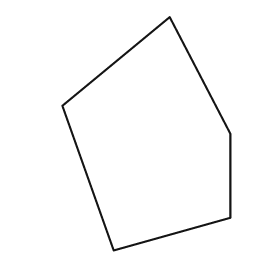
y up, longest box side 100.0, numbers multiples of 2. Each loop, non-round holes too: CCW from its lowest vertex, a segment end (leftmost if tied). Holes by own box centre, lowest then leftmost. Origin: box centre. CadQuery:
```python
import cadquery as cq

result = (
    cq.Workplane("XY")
    .moveTo(-14.0, -50.0)
    .lineTo(36.0, -36.0)
    .lineTo(36.0, 0.0)
    .lineTo(10.0, 50.0)
    .lineTo(-36.0, 12.0)
    .close()
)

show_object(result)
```